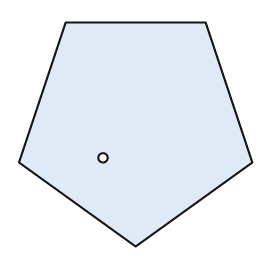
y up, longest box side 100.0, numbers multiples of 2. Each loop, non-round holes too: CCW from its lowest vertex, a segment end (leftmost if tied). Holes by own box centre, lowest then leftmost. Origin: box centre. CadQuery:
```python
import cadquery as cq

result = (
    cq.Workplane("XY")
    .moveTo(0.0, -48.0)
    .lineTo(50.0, -12.0)
    .lineTo(30.0, 48.0)
    .lineTo(-30.0, 48.0)
    .lineTo(-50.0, -12.0)
    .close()
    .moveTo(-14.0, -10.0)
    .circle(2.0)
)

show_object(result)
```